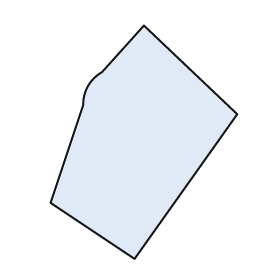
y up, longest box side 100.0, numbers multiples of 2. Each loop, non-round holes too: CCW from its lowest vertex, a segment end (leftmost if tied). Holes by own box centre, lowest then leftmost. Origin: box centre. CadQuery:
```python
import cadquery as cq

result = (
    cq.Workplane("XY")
    .moveTo(-4.0, -50.0)
    .lineTo(40.0, 12.0)
    .lineTo(0.0, 50.0)
    .lineTo(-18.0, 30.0)
    .threePointArc((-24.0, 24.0), (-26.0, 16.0))
    .lineTo(-40.0, -26.0)
    .close()
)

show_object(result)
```